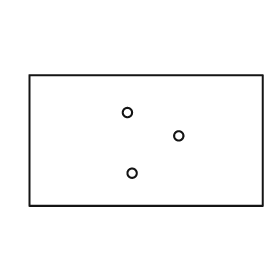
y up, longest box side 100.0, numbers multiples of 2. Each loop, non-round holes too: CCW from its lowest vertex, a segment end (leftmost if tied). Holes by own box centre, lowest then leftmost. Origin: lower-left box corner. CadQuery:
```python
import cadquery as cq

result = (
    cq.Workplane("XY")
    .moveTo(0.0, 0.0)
    .lineTo(100.0, 0.0)
    .lineTo(100.0, 56.0)
    .lineTo(0.0, 56.0)
    .close()
    .moveTo(44.0, 14.0)
    .circle(2.0)
    .moveTo(64.0, 30.0)
    .circle(2.0)
    .moveTo(42.0, 40.0)
    .circle(2.0)
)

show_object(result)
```